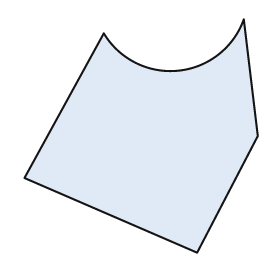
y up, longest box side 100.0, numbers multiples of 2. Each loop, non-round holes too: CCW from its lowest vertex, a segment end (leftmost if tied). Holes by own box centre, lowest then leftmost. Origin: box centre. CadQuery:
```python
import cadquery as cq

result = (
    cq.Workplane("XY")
    .moveTo(24.0, -50.0)
    .lineTo(50.0, 0.0)
    .lineTo(44.0, 50.0)
    .threePointArc((16.0, 28.0), (-16.0, 44.0))
    .lineTo(-50.0, -18.0)
    .close()
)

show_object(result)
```